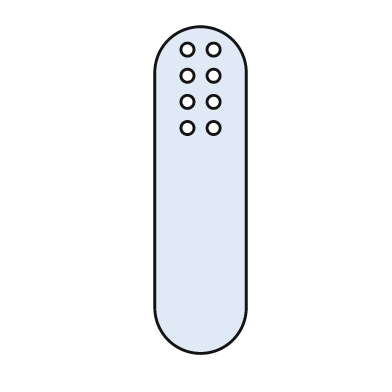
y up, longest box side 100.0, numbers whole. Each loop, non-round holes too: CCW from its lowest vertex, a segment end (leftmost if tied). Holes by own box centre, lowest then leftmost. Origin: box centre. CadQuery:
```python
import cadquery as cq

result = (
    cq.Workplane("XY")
    .moveTo(-14.0, -36.0)
    .threePointArc((0.0, -50.0), (14.0, -36.0))
    .lineTo(14.0, 36.0)
    .threePointArc((0.0, 50.0), (-14.0, 36.0))
    .close()
    .moveTo(-4.0, 19.0)
    .circle(2.0)
    .moveTo(4.0, 19.0)
    .circle(2.0)
    .moveTo(-4.0, 27.0)
    .circle(2.0)
    .moveTo(4.0, 27.0)
    .circle(2.0)
    .moveTo(-4.0, 35.0)
    .circle(2.0)
    .moveTo(4.0, 35.0)
    .circle(2.0)
    .moveTo(-4.0, 43.0)
    .circle(2.0)
    .moveTo(4.0, 43.0)
    .circle(2.0)
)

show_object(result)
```